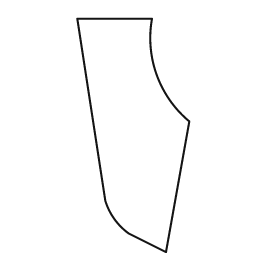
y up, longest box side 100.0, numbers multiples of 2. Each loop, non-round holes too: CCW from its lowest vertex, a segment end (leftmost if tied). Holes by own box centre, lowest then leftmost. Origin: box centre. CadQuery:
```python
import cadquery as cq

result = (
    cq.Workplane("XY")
    .moveTo(14.0, -50.0)
    .lineTo(24.0, 6.0)
    .threePointArc((10.0, 26.0), (8.0, 50.0))
    .lineTo(-24.0, 50.0)
    .lineTo(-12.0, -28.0)
    .threePointArc((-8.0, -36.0), (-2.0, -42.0))
    .close()
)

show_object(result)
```